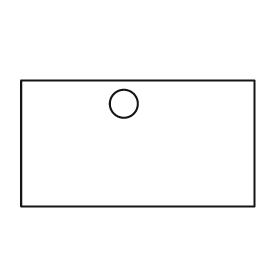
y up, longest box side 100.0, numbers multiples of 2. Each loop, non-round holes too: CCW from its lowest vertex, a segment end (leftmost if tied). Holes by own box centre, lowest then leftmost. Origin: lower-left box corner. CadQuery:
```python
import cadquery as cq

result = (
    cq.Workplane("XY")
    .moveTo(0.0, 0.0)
    .lineTo(100.0, 0.0)
    .lineTo(100.0, 54.0)
    .lineTo(0.0, 54.0)
    .close()
    .moveTo(44.0, 44.0)
    .circle(6.0)
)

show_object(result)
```